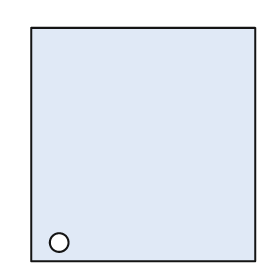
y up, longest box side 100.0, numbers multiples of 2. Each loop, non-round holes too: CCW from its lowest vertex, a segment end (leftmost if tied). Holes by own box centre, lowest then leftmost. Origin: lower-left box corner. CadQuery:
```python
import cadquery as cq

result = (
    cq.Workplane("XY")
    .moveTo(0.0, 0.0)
    .lineTo(96.0, 0.0)
    .lineTo(96.0, 100.0)
    .lineTo(0.0, 100.0)
    .close()
    .moveTo(12.0, 8.0)
    .circle(4.0)
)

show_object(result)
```